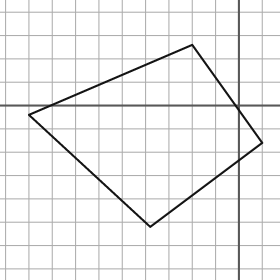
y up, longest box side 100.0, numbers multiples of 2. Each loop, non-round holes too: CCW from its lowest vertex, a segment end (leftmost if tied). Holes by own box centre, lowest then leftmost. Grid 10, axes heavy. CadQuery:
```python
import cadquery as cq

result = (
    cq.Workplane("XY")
    .moveTo(-38.0, -52.0)
    .lineTo(10.0, -16.0)
    .lineTo(-20.0, 26.0)
    .lineTo(-90.0, -4.0)
    .close()
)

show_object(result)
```